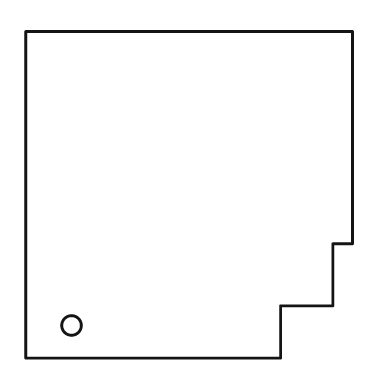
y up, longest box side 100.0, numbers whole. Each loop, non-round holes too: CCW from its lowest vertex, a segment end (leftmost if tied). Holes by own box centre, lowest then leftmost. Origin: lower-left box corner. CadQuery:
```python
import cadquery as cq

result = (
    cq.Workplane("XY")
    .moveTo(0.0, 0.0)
    .lineTo(78.0, 0.0)
    .lineTo(78.0, 16.0)
    .lineTo(94.0, 16.0)
    .lineTo(94.0, 35.0)
    .lineTo(100.0, 35.0)
    .lineTo(100.0, 100.0)
    .lineTo(0.0, 100.0)
    .close()
    .moveTo(14.0, 10.0)
    .circle(3.0)
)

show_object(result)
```